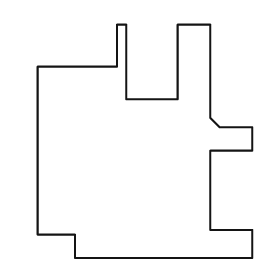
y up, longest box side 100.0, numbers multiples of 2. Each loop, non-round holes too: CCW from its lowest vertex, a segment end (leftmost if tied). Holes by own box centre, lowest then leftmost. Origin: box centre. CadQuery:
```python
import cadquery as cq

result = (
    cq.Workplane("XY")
    .moveTo(-30.0, -50.0)
    .lineTo(46.0, -50.0)
    .lineTo(46.0, -38.0)
    .lineTo(28.0, -38.0)
    .lineTo(28.0, -4.0)
    .lineTo(46.0, -4.0)
    .lineTo(46.0, 6.0)
    .lineTo(32.0, 6.0)
    .lineTo(28.0, 10.0)
    .lineTo(28.0, 50.0)
    .lineTo(14.0, 50.0)
    .lineTo(14.0, 18.0)
    .lineTo(-8.0, 18.0)
    .lineTo(-8.0, 50.0)
    .lineTo(-12.0, 50.0)
    .lineTo(-12.0, 32.0)
    .lineTo(-46.0, 32.0)
    .lineTo(-46.0, -40.0)
    .lineTo(-30.0, -40.0)
    .close()
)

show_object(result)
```